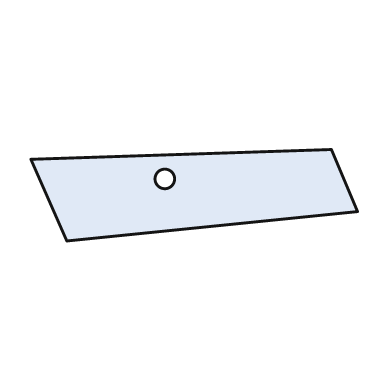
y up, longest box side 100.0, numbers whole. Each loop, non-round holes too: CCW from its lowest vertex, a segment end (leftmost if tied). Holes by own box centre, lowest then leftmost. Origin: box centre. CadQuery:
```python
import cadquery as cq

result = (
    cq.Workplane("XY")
    .moveTo(-39.0, -14.0)
    .lineTo(50.0, -5.0)
    .lineTo(42.0, 14.0)
    .lineTo(-50.0, 11.0)
    .close()
    .moveTo(-9.0, 5.0)
    .circle(3.0)
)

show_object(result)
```